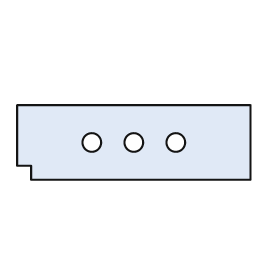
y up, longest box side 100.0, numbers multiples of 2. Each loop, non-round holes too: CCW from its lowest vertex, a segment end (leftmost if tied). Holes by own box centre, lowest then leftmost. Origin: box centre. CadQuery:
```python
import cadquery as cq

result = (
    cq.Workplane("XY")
    .moveTo(-44.0, -16.0)
    .lineTo(50.0, -16.0)
    .lineTo(50.0, 16.0)
    .lineTo(-50.0, 16.0)
    .lineTo(-50.0, -10.0)
    .lineTo(-44.0, -10.0)
    .close()
    .moveTo(-18.0, 0.0)
    .circle(4.0)
    .moveTo(0.0, 0.0)
    .circle(4.0)
    .moveTo(18.0, 0.0)
    .circle(4.0)
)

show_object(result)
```